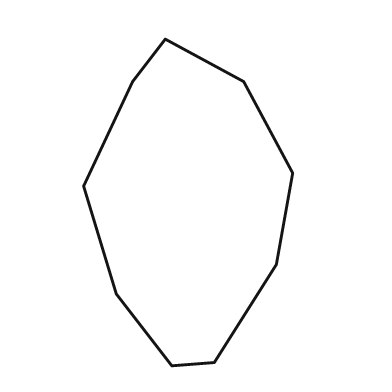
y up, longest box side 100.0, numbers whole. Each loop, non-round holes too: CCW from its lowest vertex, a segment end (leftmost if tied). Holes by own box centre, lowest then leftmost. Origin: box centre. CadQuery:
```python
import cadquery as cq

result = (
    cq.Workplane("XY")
    .moveTo(-5.0, -50.0)
    .lineTo(8.0, -49.0)
    .lineTo(27.0, -19.0)
    .lineTo(32.0, 9.0)
    .lineTo(17.0, 37.0)
    .lineTo(-7.0, 50.0)
    .lineTo(-17.0, 37.0)
    .lineTo(-32.0, 5.0)
    .lineTo(-22.0, -28.0)
    .close()
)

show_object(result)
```